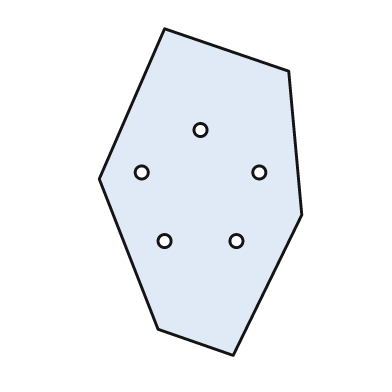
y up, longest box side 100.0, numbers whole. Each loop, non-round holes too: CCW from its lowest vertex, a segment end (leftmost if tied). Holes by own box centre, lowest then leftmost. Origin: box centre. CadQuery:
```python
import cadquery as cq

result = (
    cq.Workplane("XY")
    .moveTo(10.0, -50.0)
    .lineTo(31.0, -7.0)
    .lineTo(27.0, 37.0)
    .lineTo(-11.0, 50.0)
    .lineTo(-31.0, 4.0)
    .lineTo(-13.0, -42.0)
    .close()
    .moveTo(-11.0, -15.0)
    .circle(2.0)
    .moveTo(11.0, -15.0)
    .circle(2.0)
    .moveTo(-18.0, 6.0)
    .circle(2.0)
    .moveTo(18.0, 6.0)
    .circle(2.0)
    .moveTo(0.0, 19.0)
    .circle(2.0)
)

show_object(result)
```